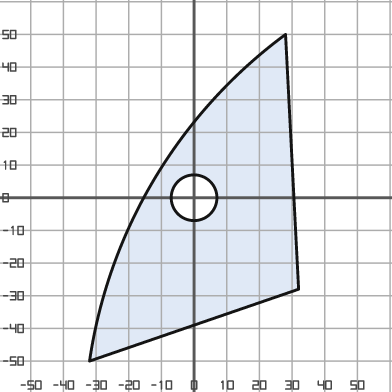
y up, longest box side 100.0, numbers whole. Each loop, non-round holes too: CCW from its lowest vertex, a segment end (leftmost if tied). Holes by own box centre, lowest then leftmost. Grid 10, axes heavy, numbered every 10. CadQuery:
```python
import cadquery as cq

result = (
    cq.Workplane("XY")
    .moveTo(-32.0, -50.0)
    .lineTo(32.0, -28.0)
    .lineTo(28.0, 50.0)
    .threePointArc((-12.0, 6.0), (-32.0, -50.0))
    .close()
    .moveTo(0.0, 0.0)
    .circle(7.0)
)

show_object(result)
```